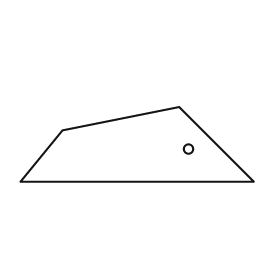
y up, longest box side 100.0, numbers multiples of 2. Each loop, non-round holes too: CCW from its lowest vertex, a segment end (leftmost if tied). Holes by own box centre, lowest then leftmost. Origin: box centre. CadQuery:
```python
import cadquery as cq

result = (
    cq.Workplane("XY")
    .moveTo(-50.0, -16.0)
    .lineTo(50.0, -16.0)
    .lineTo(18.0, 16.0)
    .lineTo(-32.0, 6.0)
    .close()
    .moveTo(22.0, -2.0)
    .circle(2.0)
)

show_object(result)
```